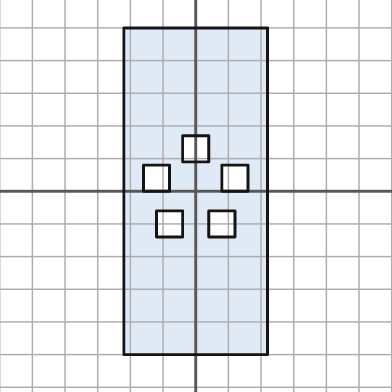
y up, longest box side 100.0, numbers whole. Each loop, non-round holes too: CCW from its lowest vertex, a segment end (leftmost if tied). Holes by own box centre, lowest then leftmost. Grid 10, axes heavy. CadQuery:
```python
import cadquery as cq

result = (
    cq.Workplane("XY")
    .moveTo(-22.0, -50.0)
    .lineTo(22.0, -50.0)
    .lineTo(22.0, 50.0)
    .lineTo(-22.0, 50.0)
    .close()
    .moveTo(-12.0, -14.0)
    .lineTo(-4.0, -14.0)
    .lineTo(-4.0, -6.0)
    .lineTo(-12.0, -6.0)
    .close()
    .moveTo(4.0, -14.0)
    .lineTo(12.0, -14.0)
    .lineTo(12.0, -6.0)
    .lineTo(4.0, -6.0)
    .close()
    .moveTo(-16.0, 0.0)
    .lineTo(-8.0, 0.0)
    .lineTo(-8.0, 8.0)
    .lineTo(-16.0, 8.0)
    .close()
    .moveTo(8.0, 0.0)
    .lineTo(16.0, 0.0)
    .lineTo(16.0, 8.0)
    .lineTo(8.0, 8.0)
    .close()
    .moveTo(-4.0, 9.0)
    .lineTo(4.0, 9.0)
    .lineTo(4.0, 17.0)
    .lineTo(-4.0, 17.0)
    .close()
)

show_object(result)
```